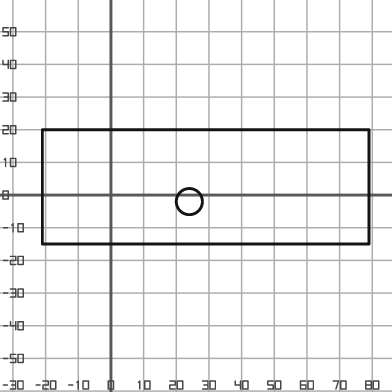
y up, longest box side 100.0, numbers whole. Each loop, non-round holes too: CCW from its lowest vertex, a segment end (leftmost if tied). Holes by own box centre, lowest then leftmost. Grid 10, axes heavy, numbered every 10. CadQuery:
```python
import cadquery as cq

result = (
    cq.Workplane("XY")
    .moveTo(-21.0, -15.0)
    .lineTo(79.0, -15.0)
    .lineTo(79.0, 20.0)
    .lineTo(-21.0, 20.0)
    .close()
    .moveTo(24.0, -2.0)
    .circle(4.0)
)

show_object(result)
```